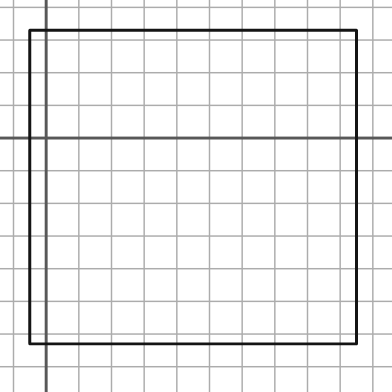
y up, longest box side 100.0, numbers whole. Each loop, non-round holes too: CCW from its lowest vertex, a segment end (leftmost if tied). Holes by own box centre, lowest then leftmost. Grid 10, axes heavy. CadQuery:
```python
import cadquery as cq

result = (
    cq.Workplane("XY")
    .moveTo(-5.0, -63.0)
    .lineTo(95.0, -63.0)
    .lineTo(95.0, 33.0)
    .lineTo(-5.0, 33.0)
    .close()
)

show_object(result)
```